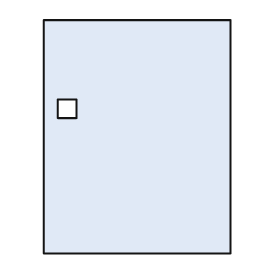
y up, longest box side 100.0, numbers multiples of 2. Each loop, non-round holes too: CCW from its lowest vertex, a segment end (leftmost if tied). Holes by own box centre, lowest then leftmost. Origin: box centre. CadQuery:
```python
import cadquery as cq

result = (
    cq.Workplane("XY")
    .moveTo(-40.0, -50.0)
    .lineTo(40.0, -50.0)
    .lineTo(40.0, 50.0)
    .lineTo(-40.0, 50.0)
    .close()
    .moveTo(-34.0, 8.0)
    .lineTo(-26.0, 8.0)
    .lineTo(-26.0, 16.0)
    .lineTo(-34.0, 16.0)
    .close()
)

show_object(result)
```